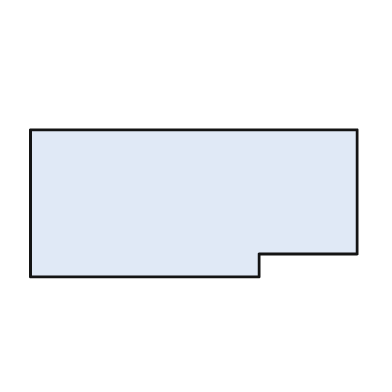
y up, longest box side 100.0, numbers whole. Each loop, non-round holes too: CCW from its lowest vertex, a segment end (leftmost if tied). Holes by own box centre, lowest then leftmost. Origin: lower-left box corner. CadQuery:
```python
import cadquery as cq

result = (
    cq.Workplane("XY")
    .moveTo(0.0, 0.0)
    .lineTo(70.0, 0.0)
    .lineTo(70.0, 7.0)
    .lineTo(100.0, 7.0)
    .lineTo(100.0, 45.0)
    .lineTo(0.0, 45.0)
    .close()
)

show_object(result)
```